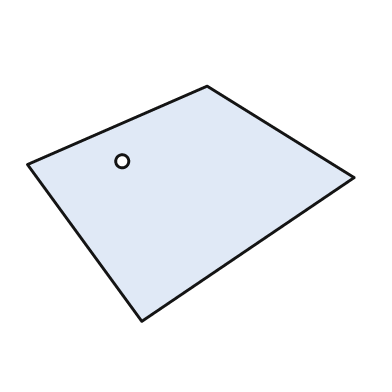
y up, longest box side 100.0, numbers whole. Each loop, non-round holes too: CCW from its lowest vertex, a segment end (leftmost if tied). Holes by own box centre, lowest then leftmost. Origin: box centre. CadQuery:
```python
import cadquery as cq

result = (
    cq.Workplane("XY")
    .moveTo(-15.0, -36.0)
    .lineTo(50.0, 8.0)
    .lineTo(5.0, 36.0)
    .lineTo(-50.0, 12.0)
    .close()
    .moveTo(-21.0, 13.0)
    .circle(2.0)
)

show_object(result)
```